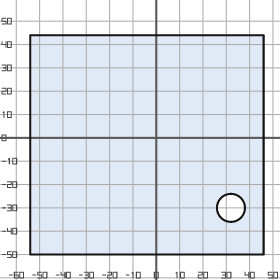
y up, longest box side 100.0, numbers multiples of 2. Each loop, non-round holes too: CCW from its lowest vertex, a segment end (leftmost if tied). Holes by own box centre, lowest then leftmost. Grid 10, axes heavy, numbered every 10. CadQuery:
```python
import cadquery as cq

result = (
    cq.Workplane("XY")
    .moveTo(-54.0, -50.0)
    .lineTo(46.0, -50.0)
    .lineTo(46.0, 44.0)
    .lineTo(-54.0, 44.0)
    .close()
    .moveTo(32.0, -30.0)
    .circle(6.0)
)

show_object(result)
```